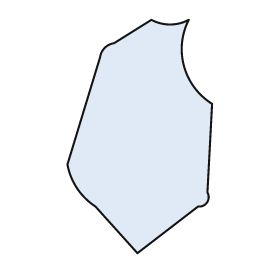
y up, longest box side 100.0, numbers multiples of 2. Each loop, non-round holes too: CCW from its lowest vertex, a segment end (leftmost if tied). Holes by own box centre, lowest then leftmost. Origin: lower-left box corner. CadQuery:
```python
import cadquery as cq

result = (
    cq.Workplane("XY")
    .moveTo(30.0, 0.0)
    .lineTo(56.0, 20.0)
    .threePointArc((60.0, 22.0), (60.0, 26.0))
    .lineTo(62.0, 64.0)
    .threePointArc((50.0, 80.0), (52.0, 100.0))
    .threePointArc((44.0, 98.0), (36.0, 100.0))
    .lineTo(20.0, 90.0)
    .threePointArc((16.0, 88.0), (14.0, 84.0))
    .lineTo(0.0, 38.0)
    .threePointArc((4.0, 28.0), (12.0, 20.0))
    .close()
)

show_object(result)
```